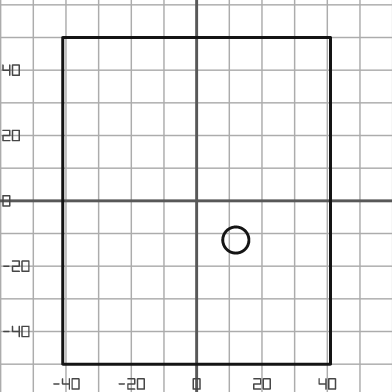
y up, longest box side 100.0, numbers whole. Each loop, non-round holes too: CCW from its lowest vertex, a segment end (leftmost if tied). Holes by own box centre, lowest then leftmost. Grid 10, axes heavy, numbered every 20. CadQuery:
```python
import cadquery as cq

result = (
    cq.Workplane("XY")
    .moveTo(-41.0, -50.0)
    .lineTo(41.0, -50.0)
    .lineTo(41.0, 50.0)
    .lineTo(-41.0, 50.0)
    .close()
    .moveTo(12.0, -12.0)
    .circle(4.0)
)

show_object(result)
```